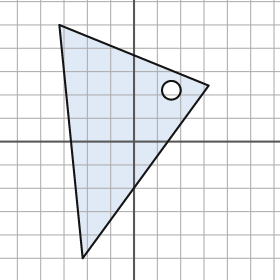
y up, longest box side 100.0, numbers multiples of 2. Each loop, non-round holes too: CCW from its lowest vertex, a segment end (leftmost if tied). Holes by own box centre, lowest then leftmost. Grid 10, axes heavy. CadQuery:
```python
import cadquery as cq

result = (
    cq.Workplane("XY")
    .moveTo(-22.0, -50.0)
    .lineTo(32.0, 24.0)
    .lineTo(-32.0, 50.0)
    .close()
    .moveTo(16.0, 22.0)
    .circle(4.0)
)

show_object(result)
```